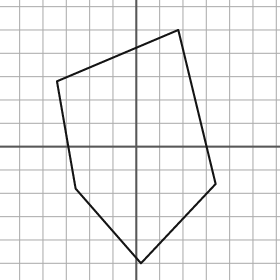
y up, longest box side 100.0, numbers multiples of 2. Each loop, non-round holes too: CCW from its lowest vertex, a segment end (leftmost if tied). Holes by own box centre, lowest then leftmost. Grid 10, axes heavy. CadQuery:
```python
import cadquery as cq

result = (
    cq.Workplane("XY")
    .moveTo(2.0, -50.0)
    .lineTo(34.0, -16.0)
    .lineTo(18.0, 50.0)
    .lineTo(-34.0, 28.0)
    .lineTo(-26.0, -18.0)
    .close()
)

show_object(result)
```